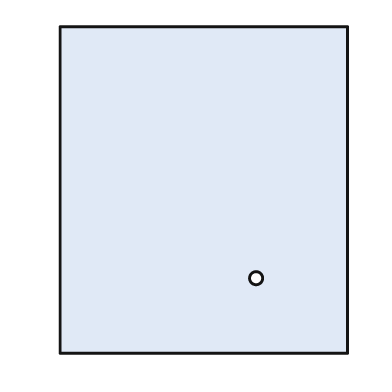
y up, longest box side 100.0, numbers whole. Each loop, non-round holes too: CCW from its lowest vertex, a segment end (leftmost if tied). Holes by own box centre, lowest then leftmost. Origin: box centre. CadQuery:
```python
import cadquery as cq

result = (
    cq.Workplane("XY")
    .moveTo(-44.0, -50.0)
    .lineTo(44.0, -50.0)
    .lineTo(44.0, 50.0)
    .lineTo(-44.0, 50.0)
    .close()
    .moveTo(16.0, -27.0)
    .circle(2.0)
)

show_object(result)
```